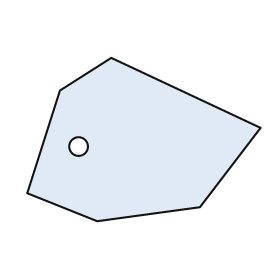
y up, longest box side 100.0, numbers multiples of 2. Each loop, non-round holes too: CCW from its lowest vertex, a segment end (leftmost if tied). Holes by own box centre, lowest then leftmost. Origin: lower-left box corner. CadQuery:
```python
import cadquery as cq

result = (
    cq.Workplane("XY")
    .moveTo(30.0, 0.0)
    .lineTo(74.0, 6.0)
    .lineTo(100.0, 40.0)
    .lineTo(36.0, 70.0)
    .lineTo(14.0, 56.0)
    .lineTo(0.0, 12.0)
    .close()
    .moveTo(22.0, 32.0)
    .circle(4.0)
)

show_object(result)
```